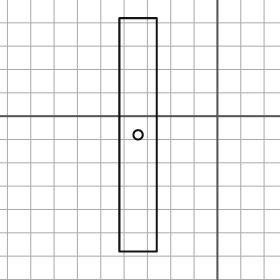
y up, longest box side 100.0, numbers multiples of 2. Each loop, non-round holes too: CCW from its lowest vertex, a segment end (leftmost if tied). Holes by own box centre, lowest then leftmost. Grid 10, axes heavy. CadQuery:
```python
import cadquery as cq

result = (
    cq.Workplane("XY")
    .moveTo(-42.0, -58.0)
    .lineTo(-26.0, -58.0)
    .lineTo(-26.0, 42.0)
    .lineTo(-42.0, 42.0)
    .close()
    .moveTo(-34.0, -8.0)
    .circle(2.0)
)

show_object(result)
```